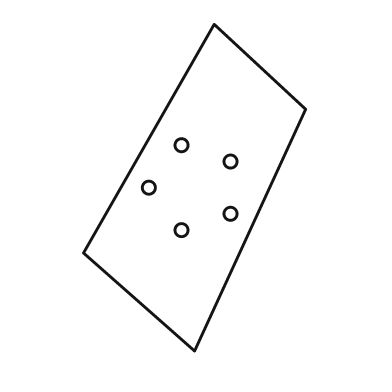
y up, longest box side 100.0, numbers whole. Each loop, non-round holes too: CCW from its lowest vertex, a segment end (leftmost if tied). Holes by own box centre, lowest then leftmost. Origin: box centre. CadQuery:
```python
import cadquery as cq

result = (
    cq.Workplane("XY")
    .moveTo(0.0, -50.0)
    .lineTo(34.0, 24.0)
    .lineTo(6.0, 50.0)
    .lineTo(-34.0, -20.0)
    .close()
    .moveTo(-4.0, -13.0)
    .circle(2.0)
    .moveTo(11.0, -8.0)
    .circle(2.0)
    .moveTo(-14.0, 0.0)
    .circle(2.0)
    .moveTo(11.0, 8.0)
    .circle(2.0)
    .moveTo(-4.0, 13.0)
    .circle(2.0)
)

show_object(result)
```